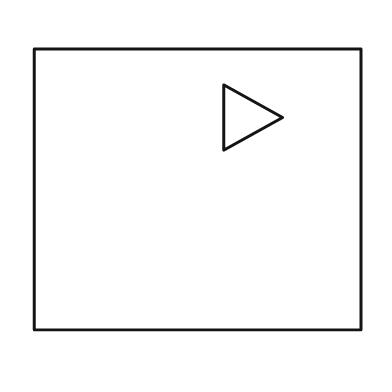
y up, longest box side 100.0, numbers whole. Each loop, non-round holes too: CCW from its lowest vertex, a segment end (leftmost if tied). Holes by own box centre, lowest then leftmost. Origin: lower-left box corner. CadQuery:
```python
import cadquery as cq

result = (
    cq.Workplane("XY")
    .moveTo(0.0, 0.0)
    .lineTo(100.0, 0.0)
    .lineTo(100.0, 86.0)
    .lineTo(0.0, 86.0)
    .close()
    .moveTo(58.0, 55.0)
    .lineTo(76.0, 65.0)
    .lineTo(58.0, 75.0)
    .close()
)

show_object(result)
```